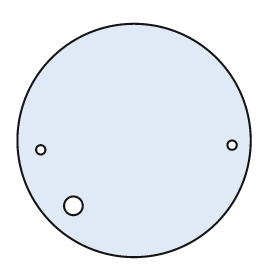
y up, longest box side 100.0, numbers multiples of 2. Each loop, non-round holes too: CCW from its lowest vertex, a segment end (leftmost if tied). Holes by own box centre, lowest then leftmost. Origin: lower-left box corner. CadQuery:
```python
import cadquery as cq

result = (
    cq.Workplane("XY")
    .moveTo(50.0, 50.0)
    .circle(50.0)
    .moveTo(24.0, 22.0)
    .circle(4.0)
    .moveTo(10.0, 46.0)
    .circle(2.0)
    .moveTo(92.0, 48.0)
    .circle(2.0)
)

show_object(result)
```